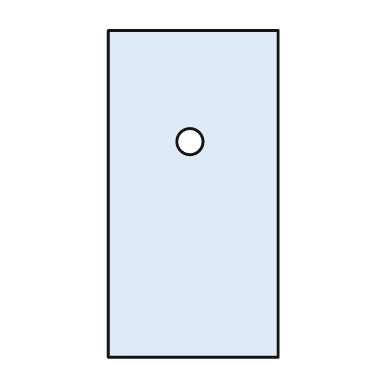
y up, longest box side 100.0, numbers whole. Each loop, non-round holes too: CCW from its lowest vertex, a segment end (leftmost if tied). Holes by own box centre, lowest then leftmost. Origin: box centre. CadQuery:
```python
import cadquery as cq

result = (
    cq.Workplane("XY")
    .moveTo(-26.0, -50.0)
    .lineTo(26.0, -50.0)
    .lineTo(26.0, 50.0)
    .lineTo(-26.0, 50.0)
    .close()
    .moveTo(-1.0, 16.0)
    .circle(4.0)
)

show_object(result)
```